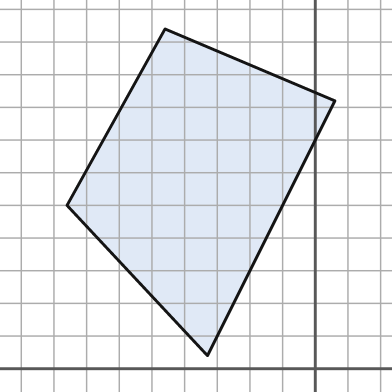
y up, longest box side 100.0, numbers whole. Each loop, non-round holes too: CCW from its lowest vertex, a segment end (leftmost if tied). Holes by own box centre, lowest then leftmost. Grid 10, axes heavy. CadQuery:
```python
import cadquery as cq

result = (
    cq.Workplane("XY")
    .moveTo(-33.0, 4.0)
    .lineTo(6.0, 82.0)
    .lineTo(-46.0, 104.0)
    .lineTo(-76.0, 50.0)
    .close()
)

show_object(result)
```